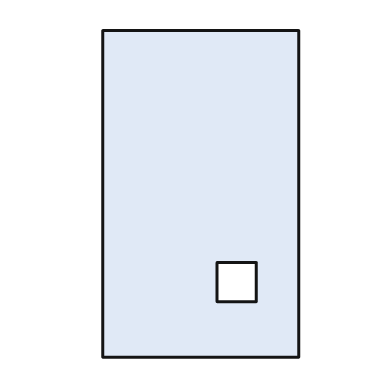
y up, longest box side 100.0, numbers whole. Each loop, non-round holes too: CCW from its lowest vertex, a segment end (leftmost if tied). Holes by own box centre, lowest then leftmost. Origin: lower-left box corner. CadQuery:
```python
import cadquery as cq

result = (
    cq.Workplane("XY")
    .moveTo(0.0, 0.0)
    .lineTo(60.0, 0.0)
    .lineTo(60.0, 100.0)
    .lineTo(0.0, 100.0)
    .close()
    .moveTo(35.0, 17.0)
    .lineTo(47.0, 17.0)
    .lineTo(47.0, 29.0)
    .lineTo(35.0, 29.0)
    .close()
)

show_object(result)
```